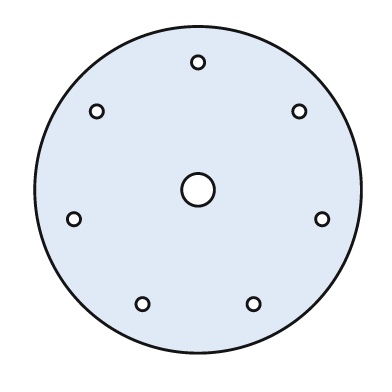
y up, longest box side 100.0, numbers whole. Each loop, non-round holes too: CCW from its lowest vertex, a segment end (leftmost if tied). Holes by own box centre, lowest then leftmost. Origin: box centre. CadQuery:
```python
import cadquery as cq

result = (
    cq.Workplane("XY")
    .moveTo(0.0, 0.0)
    .circle(50.0)
    .moveTo(-17.0, -35.0)
    .circle(2.0)
    .moveTo(17.0, -35.0)
    .circle(2.0)
    .moveTo(-38.0, -9.0)
    .circle(2.0)
    .moveTo(38.0, -9.0)
    .circle(2.0)
    .moveTo(0.0, 0.0)
    .circle(5.0)
    .moveTo(-31.0, 24.0)
    .circle(2.0)
    .moveTo(31.0, 24.0)
    .circle(2.0)
    .moveTo(0.0, 39.0)
    .circle(2.0)
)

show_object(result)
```